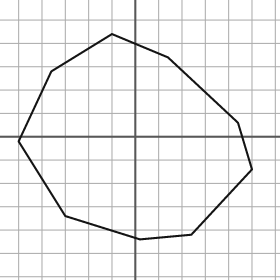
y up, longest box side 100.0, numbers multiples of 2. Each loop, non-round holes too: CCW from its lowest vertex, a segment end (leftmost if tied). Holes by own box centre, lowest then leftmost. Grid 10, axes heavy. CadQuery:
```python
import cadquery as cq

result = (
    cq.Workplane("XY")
    .moveTo(2.0, -44.0)
    .lineTo(24.0, -42.0)
    .lineTo(50.0, -14.0)
    .lineTo(44.0, 6.0)
    .lineTo(14.0, 34.0)
    .lineTo(-10.0, 44.0)
    .lineTo(-36.0, 28.0)
    .lineTo(-50.0, -2.0)
    .lineTo(-30.0, -34.0)
    .close()
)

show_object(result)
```